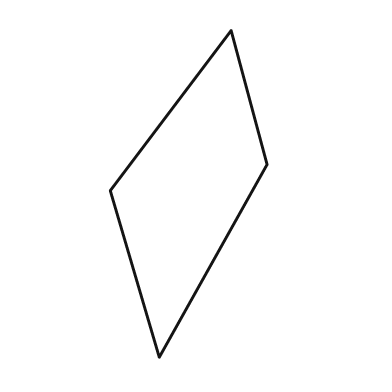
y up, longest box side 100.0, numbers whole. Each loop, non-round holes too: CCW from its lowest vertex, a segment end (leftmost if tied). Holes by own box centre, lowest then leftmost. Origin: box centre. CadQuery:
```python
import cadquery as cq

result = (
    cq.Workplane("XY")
    .moveTo(-9.0, -50.0)
    .lineTo(24.0, 9.0)
    .lineTo(13.0, 50.0)
    .lineTo(-24.0, 1.0)
    .close()
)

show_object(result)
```